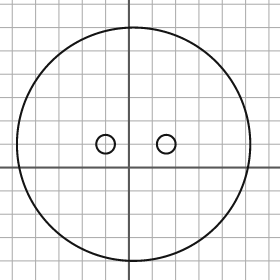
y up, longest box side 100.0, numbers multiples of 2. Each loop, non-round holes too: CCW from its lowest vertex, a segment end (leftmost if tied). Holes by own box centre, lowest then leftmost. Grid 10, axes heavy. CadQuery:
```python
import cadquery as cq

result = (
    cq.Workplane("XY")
    .moveTo(2.0, 10.0)
    .circle(50.0)
    .moveTo(-10.0, 10.0)
    .circle(4.0)
    .moveTo(16.0, 10.0)
    .circle(4.0)
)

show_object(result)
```